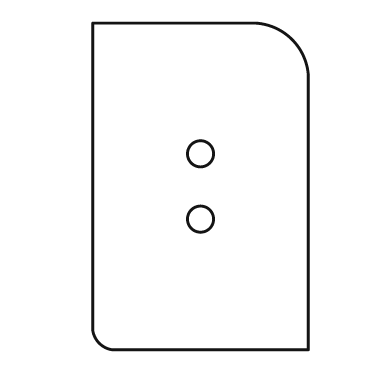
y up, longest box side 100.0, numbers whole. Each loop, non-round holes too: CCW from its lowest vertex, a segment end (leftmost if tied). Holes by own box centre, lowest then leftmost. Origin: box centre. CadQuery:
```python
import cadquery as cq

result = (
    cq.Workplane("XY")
    .moveTo(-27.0, -50.0)
    .lineTo(33.0, -50.0)
    .lineTo(33.0, 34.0)
    .threePointArc((28.0, 45.0), (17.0, 50.0))
    .lineTo(-33.0, 50.0)
    .lineTo(-33.0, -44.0)
    .threePointArc((-31.0, -48.0), (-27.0, -50.0))
    .close()
    .moveTo(0.0, -10.0)
    .circle(4.0)
    .moveTo(0.0, 10.0)
    .circle(4.0)
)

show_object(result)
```